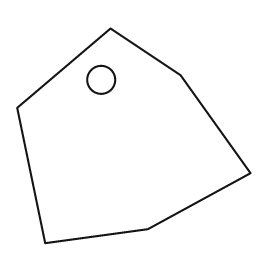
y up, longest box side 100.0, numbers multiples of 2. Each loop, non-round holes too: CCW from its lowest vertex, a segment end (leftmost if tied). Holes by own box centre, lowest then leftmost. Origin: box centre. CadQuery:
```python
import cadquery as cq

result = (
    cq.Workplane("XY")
    .moveTo(-38.0, -46.0)
    .lineTo(6.0, -40.0)
    .lineTo(50.0, -16.0)
    .lineTo(20.0, 26.0)
    .lineTo(-10.0, 46.0)
    .lineTo(-50.0, 12.0)
    .close()
    .moveTo(-14.0, 24.0)
    .circle(6.0)
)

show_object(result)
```